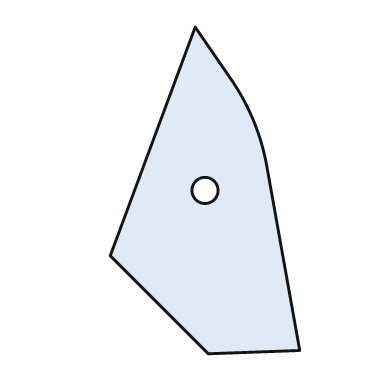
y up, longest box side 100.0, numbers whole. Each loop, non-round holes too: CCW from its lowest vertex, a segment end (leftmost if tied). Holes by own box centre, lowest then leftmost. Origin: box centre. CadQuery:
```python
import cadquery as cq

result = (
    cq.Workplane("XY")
    .moveTo(1.0, -50.0)
    .lineTo(29.0, -49.0)
    .lineTo(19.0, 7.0)
    .threePointArc((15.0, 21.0), (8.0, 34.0))
    .lineTo(-3.0, 50.0)
    .lineTo(-29.0, -20.0)
    .close()
    .moveTo(0.0, 0.0)
    .circle(4.0)
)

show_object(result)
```